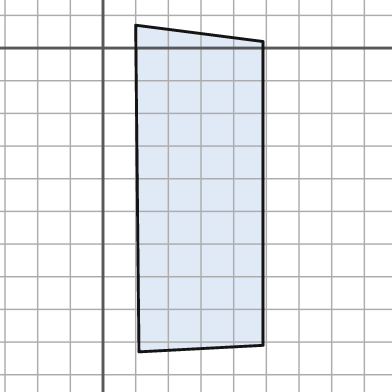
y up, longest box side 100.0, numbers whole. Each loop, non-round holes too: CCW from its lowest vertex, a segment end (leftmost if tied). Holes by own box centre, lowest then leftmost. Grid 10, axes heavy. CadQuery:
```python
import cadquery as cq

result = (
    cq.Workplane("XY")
    .moveTo(11.0, -93.0)
    .lineTo(49.0, -91.0)
    .lineTo(49.0, 2.0)
    .lineTo(10.0, 7.0)
    .close()
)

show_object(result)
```